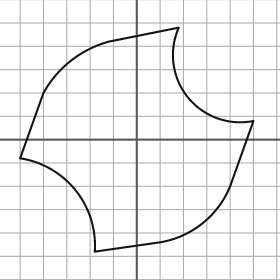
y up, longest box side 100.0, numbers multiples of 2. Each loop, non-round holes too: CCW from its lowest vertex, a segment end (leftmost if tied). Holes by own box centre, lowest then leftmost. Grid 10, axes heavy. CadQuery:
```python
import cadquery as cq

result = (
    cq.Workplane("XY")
    .moveTo(-18.0, -48.0)
    .lineTo(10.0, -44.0)
    .threePointArc((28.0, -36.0), (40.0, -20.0))
    .lineTo(50.0, 8.0)
    .threePointArc((22.0, 18.0), (18.0, 48.0))
    .lineTo(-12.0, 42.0)
    .threePointArc((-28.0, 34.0), (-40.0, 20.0))
    .lineTo(-50.0, -8.0)
    .threePointArc((-26.0, -22.0), (-18.0, -48.0))
    .close()
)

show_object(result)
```